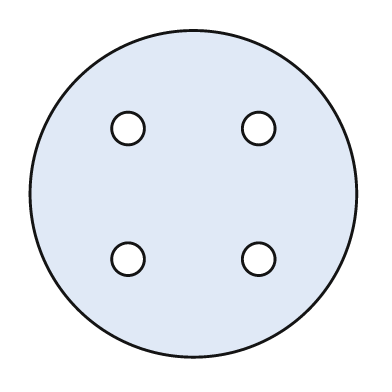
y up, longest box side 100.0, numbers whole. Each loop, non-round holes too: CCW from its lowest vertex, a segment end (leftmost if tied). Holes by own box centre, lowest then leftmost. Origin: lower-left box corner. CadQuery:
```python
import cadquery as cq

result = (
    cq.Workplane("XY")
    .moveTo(50.0, 50.0)
    .circle(50.0)
    .moveTo(30.0, 30.0)
    .circle(5.0)
    .moveTo(70.0, 30.0)
    .circle(5.0)
    .moveTo(30.0, 70.0)
    .circle(5.0)
    .moveTo(70.0, 70.0)
    .circle(5.0)
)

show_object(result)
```